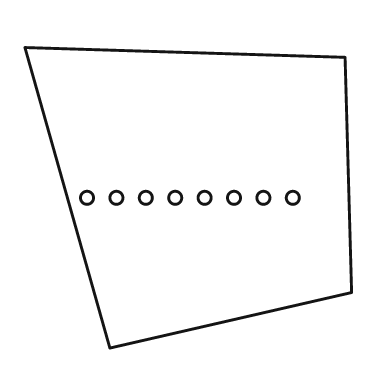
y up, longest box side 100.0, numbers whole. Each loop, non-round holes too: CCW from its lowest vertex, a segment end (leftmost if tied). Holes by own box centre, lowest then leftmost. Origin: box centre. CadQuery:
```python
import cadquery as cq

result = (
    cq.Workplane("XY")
    .moveTo(-24.0, -46.0)
    .lineTo(50.0, -29.0)
    .lineTo(48.0, 43.0)
    .lineTo(-50.0, 46.0)
    .close()
    .moveTo(-31.0, 0.0)
    .circle(2.0)
    .moveTo(-22.0, 0.0)
    .circle(2.0)
    .moveTo(-13.0, 0.0)
    .circle(2.0)
    .moveTo(-4.0, 0.0)
    .circle(2.0)
    .moveTo(5.0, 0.0)
    .circle(2.0)
    .moveTo(14.0, 0.0)
    .circle(2.0)
    .moveTo(23.0, 0.0)
    .circle(2.0)
    .moveTo(32.0, 0.0)
    .circle(2.0)
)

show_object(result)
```